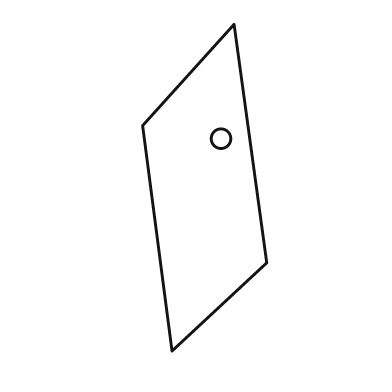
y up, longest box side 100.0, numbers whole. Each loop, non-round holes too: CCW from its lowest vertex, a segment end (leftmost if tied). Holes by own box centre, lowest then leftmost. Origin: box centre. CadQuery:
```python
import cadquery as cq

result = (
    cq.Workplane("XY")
    .moveTo(-10.0, -50.0)
    .lineTo(19.0, -23.0)
    .lineTo(9.0, 50.0)
    .lineTo(-19.0, 19.0)
    .close()
    .moveTo(5.0, 15.0)
    .circle(3.0)
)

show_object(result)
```